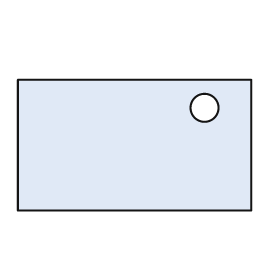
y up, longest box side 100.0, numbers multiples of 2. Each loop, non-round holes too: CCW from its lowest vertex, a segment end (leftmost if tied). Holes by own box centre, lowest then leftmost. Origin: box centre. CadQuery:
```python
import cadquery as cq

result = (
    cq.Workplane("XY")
    .moveTo(-50.0, -28.0)
    .lineTo(50.0, -28.0)
    .lineTo(50.0, 28.0)
    .lineTo(-50.0, 28.0)
    .close()
    .moveTo(30.0, 16.0)
    .circle(6.0)
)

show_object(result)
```